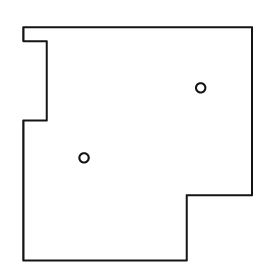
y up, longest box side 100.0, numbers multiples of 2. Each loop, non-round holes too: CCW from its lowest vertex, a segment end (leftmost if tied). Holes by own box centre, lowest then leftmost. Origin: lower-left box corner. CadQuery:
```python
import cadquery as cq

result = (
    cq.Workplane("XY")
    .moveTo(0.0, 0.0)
    .lineTo(70.0, 0.0)
    .lineTo(70.0, 28.0)
    .lineTo(98.0, 28.0)
    .lineTo(98.0, 100.0)
    .lineTo(0.0, 100.0)
    .lineTo(0.0, 94.0)
    .lineTo(10.0, 94.0)
    .lineTo(10.0, 60.0)
    .lineTo(0.0, 60.0)
    .close()
    .moveTo(26.0, 44.0)
    .circle(2.0)
    .moveTo(76.0, 74.0)
    .circle(2.0)
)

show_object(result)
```